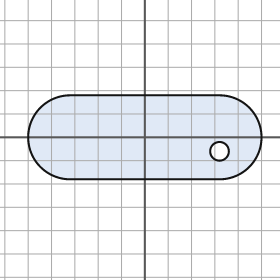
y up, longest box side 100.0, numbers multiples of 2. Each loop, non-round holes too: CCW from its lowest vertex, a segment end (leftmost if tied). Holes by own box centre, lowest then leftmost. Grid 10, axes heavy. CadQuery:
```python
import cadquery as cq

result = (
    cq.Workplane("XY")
    .moveTo(-32.0, -18.0)
    .lineTo(32.0, -18.0)
    .threePointArc((50.0, 0.0), (32.0, 18.0))
    .lineTo(-32.0, 18.0)
    .threePointArc((-50.0, 0.0), (-32.0, -18.0))
    .close()
    .moveTo(32.0, -6.0)
    .circle(4.0)
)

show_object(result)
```